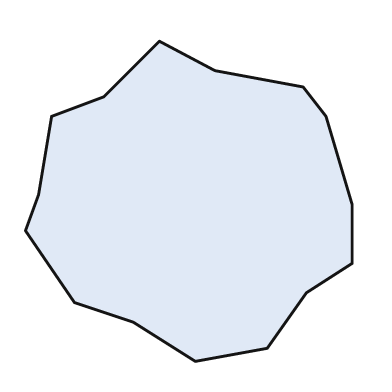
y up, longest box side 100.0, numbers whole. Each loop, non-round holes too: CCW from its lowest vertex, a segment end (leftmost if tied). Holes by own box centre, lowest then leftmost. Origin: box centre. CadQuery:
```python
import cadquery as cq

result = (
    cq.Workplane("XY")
    .moveTo(2.0, -49.0)
    .lineTo(24.0, -45.0)
    .lineTo(36.0, -28.0)
    .lineTo(50.0, -19.0)
    .lineTo(50.0, -1.0)
    .lineTo(42.0, 26.0)
    .lineTo(35.0, 35.0)
    .lineTo(8.0, 40.0)
    .lineTo(-9.0, 49.0)
    .lineTo(-26.0, 32.0)
    .lineTo(-42.0, 26.0)
    .lineTo(-46.0, 2.0)
    .lineTo(-50.0, -9.0)
    .lineTo(-35.0, -31.0)
    .lineTo(-17.0, -37.0)
    .close()
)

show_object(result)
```